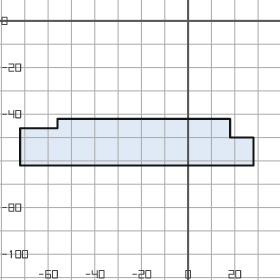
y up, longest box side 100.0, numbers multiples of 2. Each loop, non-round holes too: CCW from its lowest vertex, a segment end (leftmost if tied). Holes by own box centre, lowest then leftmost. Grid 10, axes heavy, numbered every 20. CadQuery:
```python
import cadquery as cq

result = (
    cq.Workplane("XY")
    .moveTo(-72.0, -62.0)
    .lineTo(28.0, -62.0)
    .lineTo(28.0, -50.0)
    .lineTo(18.0, -50.0)
    .lineTo(18.0, -42.0)
    .lineTo(-56.0, -42.0)
    .lineTo(-56.0, -46.0)
    .lineTo(-72.0, -46.0)
    .close()
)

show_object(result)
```